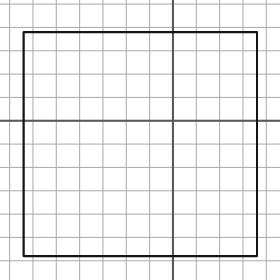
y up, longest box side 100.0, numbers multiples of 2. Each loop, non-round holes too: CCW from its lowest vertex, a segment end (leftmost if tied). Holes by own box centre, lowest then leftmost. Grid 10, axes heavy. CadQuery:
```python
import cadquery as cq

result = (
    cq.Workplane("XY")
    .moveTo(-64.0, -58.0)
    .lineTo(36.0, -58.0)
    .lineTo(36.0, 38.0)
    .lineTo(-64.0, 38.0)
    .close()
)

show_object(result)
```